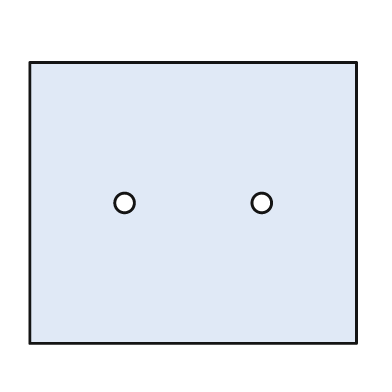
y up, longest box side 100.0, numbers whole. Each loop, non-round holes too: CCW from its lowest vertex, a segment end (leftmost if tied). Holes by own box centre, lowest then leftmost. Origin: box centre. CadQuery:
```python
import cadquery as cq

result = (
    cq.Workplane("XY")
    .moveTo(-50.0, -43.0)
    .lineTo(50.0, -43.0)
    .lineTo(50.0, 43.0)
    .lineTo(-50.0, 43.0)
    .close()
    .moveTo(-21.0, 0.0)
    .circle(3.0)
    .moveTo(21.0, 0.0)
    .circle(3.0)
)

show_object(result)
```